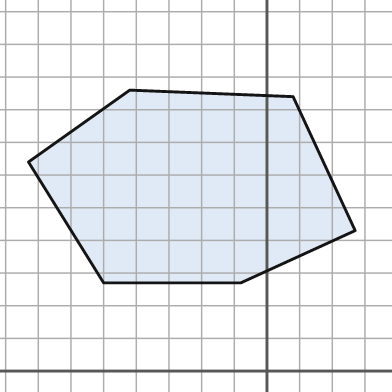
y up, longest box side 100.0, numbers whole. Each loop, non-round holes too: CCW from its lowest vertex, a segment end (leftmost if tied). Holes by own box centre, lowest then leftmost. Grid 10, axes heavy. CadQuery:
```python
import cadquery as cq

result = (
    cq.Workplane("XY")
    .moveTo(-50.0, 27.0)
    .lineTo(-8.0, 27.0)
    .lineTo(27.0, 43.0)
    .lineTo(8.0, 84.0)
    .lineTo(-42.0, 86.0)
    .lineTo(-73.0, 64.0)
    .close()
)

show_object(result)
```